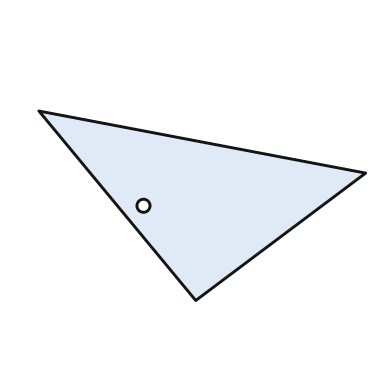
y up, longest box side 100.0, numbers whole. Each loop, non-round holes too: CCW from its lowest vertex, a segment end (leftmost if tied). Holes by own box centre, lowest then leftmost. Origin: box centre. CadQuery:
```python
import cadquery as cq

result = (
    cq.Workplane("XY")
    .moveTo(-2.0, -29.0)
    .lineTo(50.0, 10.0)
    .lineTo(-50.0, 29.0)
    .close()
    .moveTo(-18.0, 0.0)
    .circle(2.0)
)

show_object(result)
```